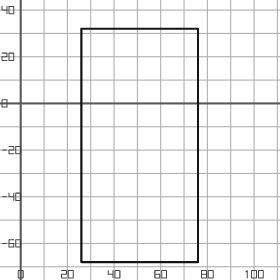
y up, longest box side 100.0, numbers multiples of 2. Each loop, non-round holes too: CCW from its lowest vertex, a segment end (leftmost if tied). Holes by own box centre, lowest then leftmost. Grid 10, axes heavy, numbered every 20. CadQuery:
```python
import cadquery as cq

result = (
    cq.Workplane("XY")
    .moveTo(26.0, -68.0)
    .lineTo(76.0, -68.0)
    .lineTo(76.0, 32.0)
    .lineTo(26.0, 32.0)
    .close()
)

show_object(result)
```